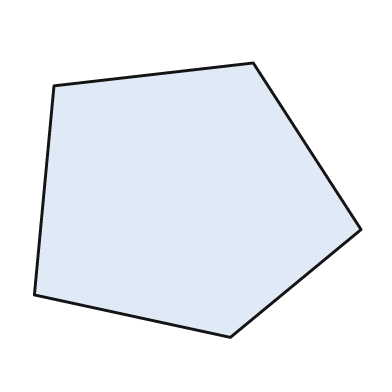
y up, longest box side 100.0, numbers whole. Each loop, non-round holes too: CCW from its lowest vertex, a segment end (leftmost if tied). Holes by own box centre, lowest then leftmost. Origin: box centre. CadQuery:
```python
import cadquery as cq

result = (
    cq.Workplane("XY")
    .moveTo(10.0, -42.0)
    .lineTo(50.0, -9.0)
    .lineTo(17.0, 42.0)
    .lineTo(-44.0, 35.0)
    .lineTo(-50.0, -29.0)
    .close()
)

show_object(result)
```